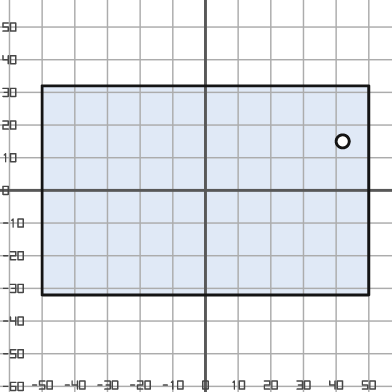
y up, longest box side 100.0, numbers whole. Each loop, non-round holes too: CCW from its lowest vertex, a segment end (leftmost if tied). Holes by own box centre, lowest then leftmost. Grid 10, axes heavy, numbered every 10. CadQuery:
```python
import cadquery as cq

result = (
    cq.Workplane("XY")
    .moveTo(-50.0, -32.0)
    .lineTo(50.0, -32.0)
    .lineTo(50.0, 32.0)
    .lineTo(-50.0, 32.0)
    .close()
    .moveTo(42.0, 15.0)
    .circle(2.0)
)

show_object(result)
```